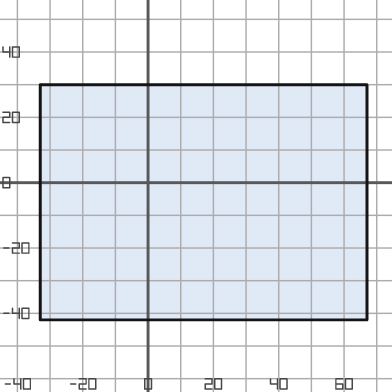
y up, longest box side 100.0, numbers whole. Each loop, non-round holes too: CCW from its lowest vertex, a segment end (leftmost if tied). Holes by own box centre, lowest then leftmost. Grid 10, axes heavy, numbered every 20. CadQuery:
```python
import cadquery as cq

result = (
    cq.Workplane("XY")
    .moveTo(-33.0, -42.0)
    .lineTo(67.0, -42.0)
    .lineTo(67.0, 30.0)
    .lineTo(-33.0, 30.0)
    .close()
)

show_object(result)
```